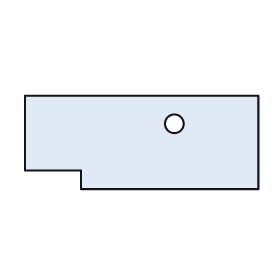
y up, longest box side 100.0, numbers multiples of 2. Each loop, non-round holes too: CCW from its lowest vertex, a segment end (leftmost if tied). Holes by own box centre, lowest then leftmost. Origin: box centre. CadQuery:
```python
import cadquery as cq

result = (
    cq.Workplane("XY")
    .moveTo(-26.0, -20.0)
    .lineTo(50.0, -20.0)
    .lineTo(50.0, 20.0)
    .lineTo(-50.0, 20.0)
    .lineTo(-50.0, -12.0)
    .lineTo(-26.0, -12.0)
    .close()
    .moveTo(14.0, 8.0)
    .circle(4.0)
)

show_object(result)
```